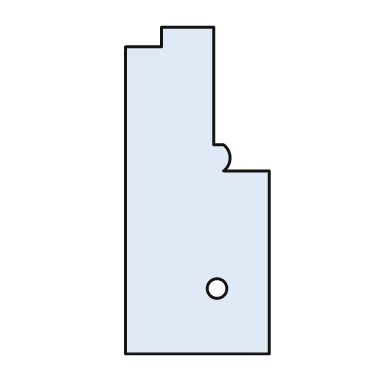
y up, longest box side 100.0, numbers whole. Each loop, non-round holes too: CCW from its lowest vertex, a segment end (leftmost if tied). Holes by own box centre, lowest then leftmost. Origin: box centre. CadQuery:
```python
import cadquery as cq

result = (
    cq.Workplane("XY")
    .moveTo(-22.0, -50.0)
    .lineTo(22.0, -50.0)
    .lineTo(22.0, 6.0)
    .lineTo(8.0, 6.0)
    .threePointArc((10.0, 10.0), (8.0, 14.0))
    .lineTo(5.0, 14.0)
    .lineTo(5.0, 50.0)
    .lineTo(-11.0, 50.0)
    .lineTo(-11.0, 44.0)
    .lineTo(-22.0, 44.0)
    .close()
    .moveTo(6.0, -30.0)
    .circle(3.0)
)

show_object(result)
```